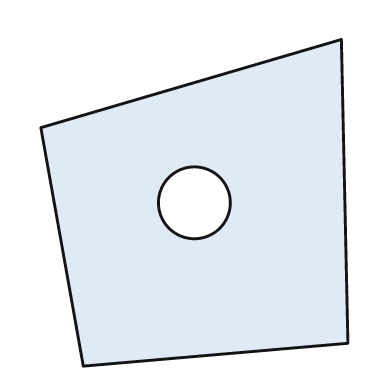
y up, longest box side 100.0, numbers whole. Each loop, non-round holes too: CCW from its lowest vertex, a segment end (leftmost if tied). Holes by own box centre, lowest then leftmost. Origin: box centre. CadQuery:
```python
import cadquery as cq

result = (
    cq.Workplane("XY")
    .moveTo(-34.0, -50.0)
    .lineTo(47.0, -43.0)
    .lineTo(45.0, 50.0)
    .lineTo(-47.0, 23.0)
    .close()
    .moveTo(0.0, 0.0)
    .circle(11.0)
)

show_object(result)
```